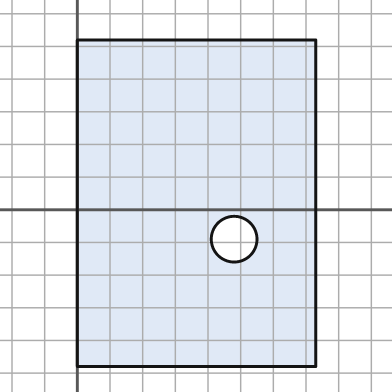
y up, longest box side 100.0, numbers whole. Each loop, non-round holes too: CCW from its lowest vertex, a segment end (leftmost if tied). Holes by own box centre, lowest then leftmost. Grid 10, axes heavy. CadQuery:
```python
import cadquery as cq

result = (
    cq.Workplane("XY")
    .moveTo(0.0, -48.0)
    .lineTo(73.0, -48.0)
    .lineTo(73.0, 52.0)
    .lineTo(0.0, 52.0)
    .close()
    .moveTo(48.0, -9.0)
    .circle(7.0)
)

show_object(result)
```